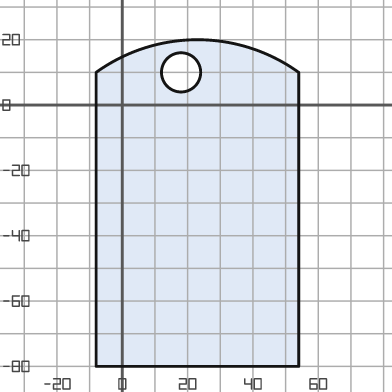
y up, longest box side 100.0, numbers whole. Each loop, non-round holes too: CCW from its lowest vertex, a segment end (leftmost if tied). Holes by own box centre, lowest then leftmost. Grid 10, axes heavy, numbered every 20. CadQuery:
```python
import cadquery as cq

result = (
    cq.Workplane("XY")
    .moveTo(-8.0, -80.0)
    .lineTo(54.0, -80.0)
    .lineTo(54.0, 10.0)
    .threePointArc((23.0, 20.0), (-8.0, 10.0))
    .close()
    .moveTo(18.0, 10.0)
    .circle(6.0)
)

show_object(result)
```